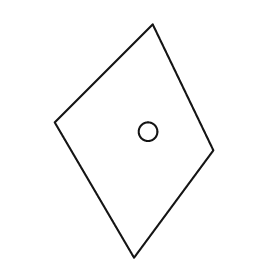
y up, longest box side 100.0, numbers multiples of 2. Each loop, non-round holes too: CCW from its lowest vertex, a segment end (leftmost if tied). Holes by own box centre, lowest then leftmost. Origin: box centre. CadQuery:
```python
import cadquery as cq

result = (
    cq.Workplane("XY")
    .moveTo(0.0, -50.0)
    .lineTo(34.0, -4.0)
    .lineTo(8.0, 50.0)
    .lineTo(-34.0, 8.0)
    .close()
    .moveTo(6.0, 4.0)
    .circle(4.0)
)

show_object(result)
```